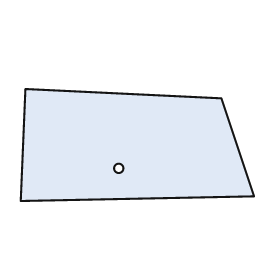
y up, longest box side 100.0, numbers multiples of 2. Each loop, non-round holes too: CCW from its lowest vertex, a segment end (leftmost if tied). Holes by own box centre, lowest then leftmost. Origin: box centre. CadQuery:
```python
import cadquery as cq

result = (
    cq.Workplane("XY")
    .moveTo(-50.0, -24.0)
    .lineTo(50.0, -22.0)
    .lineTo(36.0, 20.0)
    .lineTo(-48.0, 24.0)
    .close()
    .moveTo(-8.0, -10.0)
    .circle(2.0)
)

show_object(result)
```